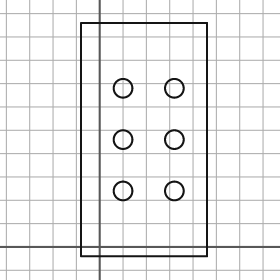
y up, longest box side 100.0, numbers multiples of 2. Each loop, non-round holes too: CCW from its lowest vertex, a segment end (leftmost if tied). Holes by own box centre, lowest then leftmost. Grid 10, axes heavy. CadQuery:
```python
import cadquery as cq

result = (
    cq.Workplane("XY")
    .moveTo(-8.0, -4.0)
    .lineTo(46.0, -4.0)
    .lineTo(46.0, 96.0)
    .lineTo(-8.0, 96.0)
    .close()
    .moveTo(10.0, 24.0)
    .circle(4.0)
    .moveTo(32.0, 24.0)
    .circle(4.0)
    .moveTo(10.0, 46.0)
    .circle(4.0)
    .moveTo(32.0, 46.0)
    .circle(4.0)
    .moveTo(10.0, 68.0)
    .circle(4.0)
    .moveTo(32.0, 68.0)
    .circle(4.0)
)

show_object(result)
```